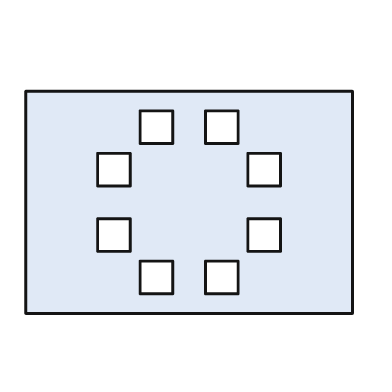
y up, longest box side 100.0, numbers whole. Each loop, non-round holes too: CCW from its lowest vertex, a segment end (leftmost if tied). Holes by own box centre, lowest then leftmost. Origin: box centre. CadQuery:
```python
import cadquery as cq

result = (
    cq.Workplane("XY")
    .moveTo(-50.0, -34.0)
    .lineTo(50.0, -34.0)
    .lineTo(50.0, 34.0)
    .lineTo(-50.0, 34.0)
    .close()
    .moveTo(-15.0, -28.0)
    .lineTo(-5.0, -28.0)
    .lineTo(-5.0, -18.0)
    .lineTo(-15.0, -18.0)
    .close()
    .moveTo(5.0, -28.0)
    .lineTo(15.0, -28.0)
    .lineTo(15.0, -18.0)
    .lineTo(5.0, -18.0)
    .close()
    .moveTo(-28.0, -15.0)
    .lineTo(-18.0, -15.0)
    .lineTo(-18.0, -5.0)
    .lineTo(-28.0, -5.0)
    .close()
    .moveTo(18.0, -15.0)
    .lineTo(28.0, -15.0)
    .lineTo(28.0, -5.0)
    .lineTo(18.0, -5.0)
    .close()
    .moveTo(-28.0, 5.0)
    .lineTo(-18.0, 5.0)
    .lineTo(-18.0, 15.0)
    .lineTo(-28.0, 15.0)
    .close()
    .moveTo(18.0, 5.0)
    .lineTo(28.0, 5.0)
    .lineTo(28.0, 15.0)
    .lineTo(18.0, 15.0)
    .close()
    .moveTo(-15.0, 18.0)
    .lineTo(-5.0, 18.0)
    .lineTo(-5.0, 28.0)
    .lineTo(-15.0, 28.0)
    .close()
    .moveTo(5.0, 18.0)
    .lineTo(15.0, 18.0)
    .lineTo(15.0, 28.0)
    .lineTo(5.0, 28.0)
    .close()
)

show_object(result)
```